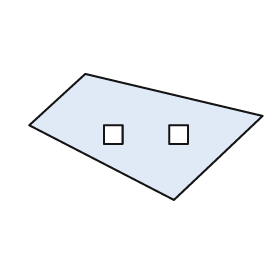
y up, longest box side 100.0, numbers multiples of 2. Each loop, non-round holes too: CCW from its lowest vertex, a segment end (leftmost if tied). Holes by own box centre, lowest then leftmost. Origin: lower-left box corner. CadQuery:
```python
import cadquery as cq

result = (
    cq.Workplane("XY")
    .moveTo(62.0, 0.0)
    .lineTo(100.0, 36.0)
    .lineTo(24.0, 54.0)
    .lineTo(0.0, 32.0)
    .close()
    .moveTo(32.0, 24.0)
    .lineTo(40.0, 24.0)
    .lineTo(40.0, 32.0)
    .lineTo(32.0, 32.0)
    .close()
    .moveTo(60.0, 24.0)
    .lineTo(68.0, 24.0)
    .lineTo(68.0, 32.0)
    .lineTo(60.0, 32.0)
    .close()
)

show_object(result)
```